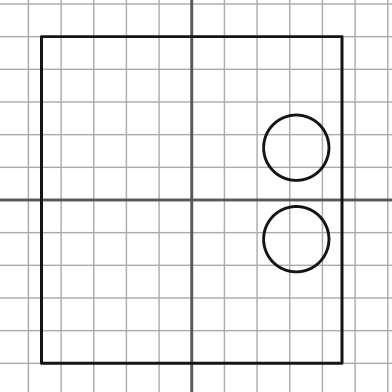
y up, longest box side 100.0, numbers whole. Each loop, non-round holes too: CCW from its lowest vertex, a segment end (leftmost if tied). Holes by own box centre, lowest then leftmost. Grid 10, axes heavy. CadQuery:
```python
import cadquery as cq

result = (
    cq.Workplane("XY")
    .moveTo(-46.0, -50.0)
    .lineTo(46.0, -50.0)
    .lineTo(46.0, 50.0)
    .lineTo(-46.0, 50.0)
    .close()
    .moveTo(32.0, -12.0)
    .circle(10.0)
    .moveTo(32.0, 16.0)
    .circle(10.0)
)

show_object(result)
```